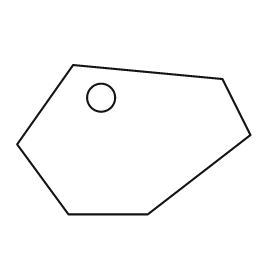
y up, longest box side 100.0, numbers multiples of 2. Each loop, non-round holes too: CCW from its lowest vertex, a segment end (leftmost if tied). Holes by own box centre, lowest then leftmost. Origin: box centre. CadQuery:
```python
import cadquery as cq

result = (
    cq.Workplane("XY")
    .moveTo(-28.0, -32.0)
    .lineTo(6.0, -32.0)
    .lineTo(50.0, 2.0)
    .lineTo(38.0, 26.0)
    .lineTo(-26.0, 32.0)
    .lineTo(-50.0, -2.0)
    .close()
    .moveTo(-14.0, 18.0)
    .circle(6.0)
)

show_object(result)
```